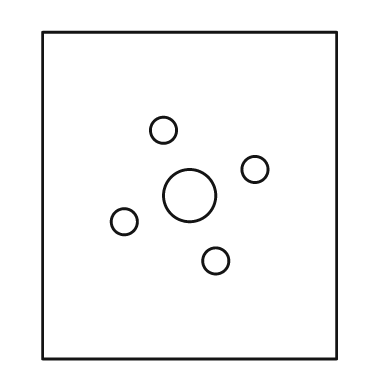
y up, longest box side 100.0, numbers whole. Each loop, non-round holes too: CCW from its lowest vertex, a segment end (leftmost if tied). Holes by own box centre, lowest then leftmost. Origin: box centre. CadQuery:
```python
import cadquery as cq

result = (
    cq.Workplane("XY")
    .moveTo(-45.0, -50.0)
    .lineTo(45.0, -50.0)
    .lineTo(45.0, 50.0)
    .lineTo(-45.0, 50.0)
    .close()
    .moveTo(8.0, -20.0)
    .circle(4.0)
    .moveTo(-20.0, -8.0)
    .circle(4.0)
    .moveTo(0.0, 0.0)
    .circle(8.0)
    .moveTo(20.0, 8.0)
    .circle(4.0)
    .moveTo(-8.0, 20.0)
    .circle(4.0)
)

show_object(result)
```